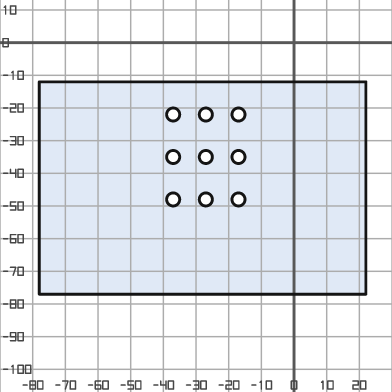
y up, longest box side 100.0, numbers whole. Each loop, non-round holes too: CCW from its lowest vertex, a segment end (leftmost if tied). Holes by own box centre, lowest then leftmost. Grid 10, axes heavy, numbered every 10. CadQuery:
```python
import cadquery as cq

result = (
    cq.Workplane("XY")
    .moveTo(-78.0, -77.0)
    .lineTo(22.0, -77.0)
    .lineTo(22.0, -12.0)
    .lineTo(-78.0, -12.0)
    .close()
    .moveTo(-37.0, -48.0)
    .circle(2.0)
    .moveTo(-27.0, -48.0)
    .circle(2.0)
    .moveTo(-17.0, -48.0)
    .circle(2.0)
    .moveTo(-37.0, -35.0)
    .circle(2.0)
    .moveTo(-27.0, -35.0)
    .circle(2.0)
    .moveTo(-17.0, -35.0)
    .circle(2.0)
    .moveTo(-37.0, -22.0)
    .circle(2.0)
    .moveTo(-27.0, -22.0)
    .circle(2.0)
    .moveTo(-17.0, -22.0)
    .circle(2.0)
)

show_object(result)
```